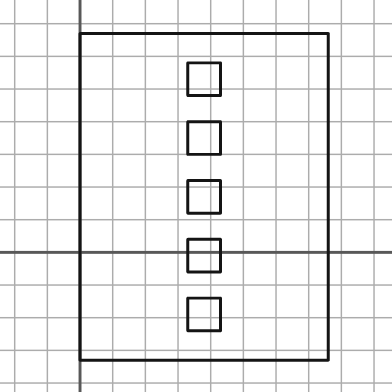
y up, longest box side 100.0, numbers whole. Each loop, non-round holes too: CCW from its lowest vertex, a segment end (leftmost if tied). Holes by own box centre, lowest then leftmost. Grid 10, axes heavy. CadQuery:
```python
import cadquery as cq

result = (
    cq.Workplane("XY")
    .moveTo(0.0, -33.0)
    .lineTo(76.0, -33.0)
    .lineTo(76.0, 67.0)
    .lineTo(0.0, 67.0)
    .close()
    .moveTo(33.0, -24.0)
    .lineTo(43.0, -24.0)
    .lineTo(43.0, -14.0)
    .lineTo(33.0, -14.0)
    .close()
    .moveTo(33.0, -6.0)
    .lineTo(43.0, -6.0)
    .lineTo(43.0, 4.0)
    .lineTo(33.0, 4.0)
    .close()
    .moveTo(33.0, 12.0)
    .lineTo(43.0, 12.0)
    .lineTo(43.0, 22.0)
    .lineTo(33.0, 22.0)
    .close()
    .moveTo(33.0, 30.0)
    .lineTo(43.0, 30.0)
    .lineTo(43.0, 40.0)
    .lineTo(33.0, 40.0)
    .close()
    .moveTo(33.0, 48.0)
    .lineTo(43.0, 48.0)
    .lineTo(43.0, 58.0)
    .lineTo(33.0, 58.0)
    .close()
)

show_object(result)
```